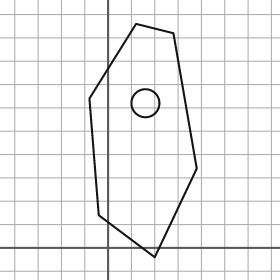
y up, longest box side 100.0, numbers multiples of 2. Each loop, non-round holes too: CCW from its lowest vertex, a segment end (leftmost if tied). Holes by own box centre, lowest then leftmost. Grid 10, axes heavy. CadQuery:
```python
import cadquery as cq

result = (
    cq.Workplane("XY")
    .moveTo(20.0, -4.0)
    .lineTo(38.0, 34.0)
    .lineTo(28.0, 92.0)
    .lineTo(12.0, 96.0)
    .lineTo(-8.0, 64.0)
    .lineTo(-4.0, 14.0)
    .close()
    .moveTo(16.0, 62.0)
    .circle(6.0)
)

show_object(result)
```